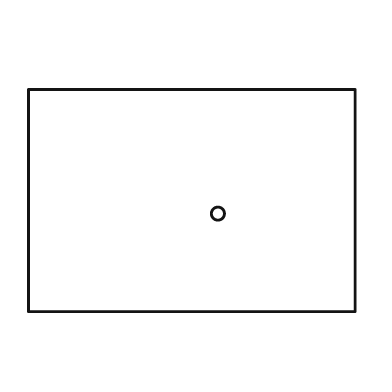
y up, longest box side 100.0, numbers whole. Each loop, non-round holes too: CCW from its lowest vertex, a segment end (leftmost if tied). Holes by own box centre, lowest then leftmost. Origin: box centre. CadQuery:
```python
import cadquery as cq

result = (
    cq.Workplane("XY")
    .moveTo(-50.0, -34.0)
    .lineTo(50.0, -34.0)
    .lineTo(50.0, 34.0)
    .lineTo(-50.0, 34.0)
    .close()
    .moveTo(8.0, -4.0)
    .circle(2.0)
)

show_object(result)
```